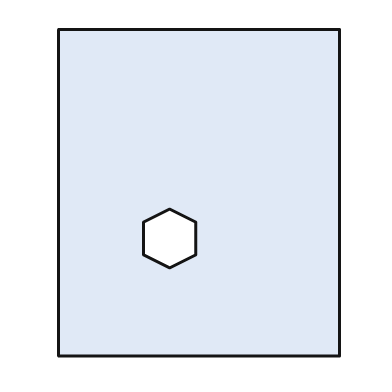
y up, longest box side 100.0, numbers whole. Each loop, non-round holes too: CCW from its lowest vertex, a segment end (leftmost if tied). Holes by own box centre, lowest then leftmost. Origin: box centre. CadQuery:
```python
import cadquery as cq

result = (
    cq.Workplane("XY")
    .moveTo(-43.0, -50.0)
    .lineTo(43.0, -50.0)
    .lineTo(43.0, 50.0)
    .lineTo(-43.0, 50.0)
    .close()
    .moveTo(-9.0, -23.0)
    .lineTo(-1.0, -19.0)
    .lineTo(-1.0, -9.0)
    .lineTo(-9.0, -5.0)
    .lineTo(-17.0, -9.0)
    .lineTo(-17.0, -19.0)
    .close()
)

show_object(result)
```